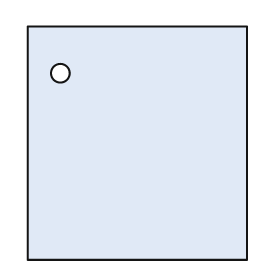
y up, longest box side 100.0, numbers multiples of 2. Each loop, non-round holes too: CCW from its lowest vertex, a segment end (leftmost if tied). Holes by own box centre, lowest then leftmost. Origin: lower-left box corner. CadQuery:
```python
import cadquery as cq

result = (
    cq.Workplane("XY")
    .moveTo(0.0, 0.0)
    .lineTo(94.0, 0.0)
    .lineTo(94.0, 100.0)
    .lineTo(0.0, 100.0)
    .close()
    .moveTo(14.0, 80.0)
    .circle(4.0)
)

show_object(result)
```